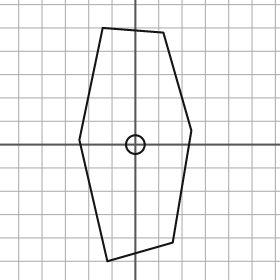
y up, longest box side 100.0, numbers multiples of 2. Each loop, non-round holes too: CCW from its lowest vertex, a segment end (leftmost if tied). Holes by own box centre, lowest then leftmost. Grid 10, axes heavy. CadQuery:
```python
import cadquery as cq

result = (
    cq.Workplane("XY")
    .moveTo(-12.0, -50.0)
    .lineTo(16.0, -42.0)
    .lineTo(24.0, 6.0)
    .lineTo(12.0, 48.0)
    .lineTo(-14.0, 50.0)
    .lineTo(-24.0, 2.0)
    .close()
    .moveTo(0.0, 0.0)
    .circle(4.0)
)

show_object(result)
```